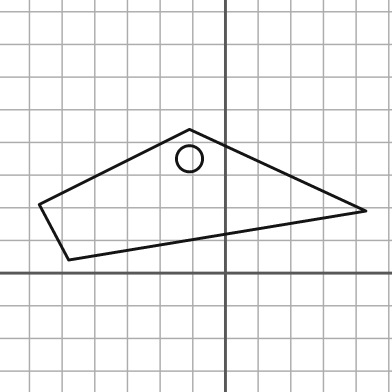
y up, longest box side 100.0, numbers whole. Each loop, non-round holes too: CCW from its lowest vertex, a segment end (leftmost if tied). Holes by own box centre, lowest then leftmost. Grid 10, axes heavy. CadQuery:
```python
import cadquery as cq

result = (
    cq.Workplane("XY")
    .moveTo(-48.0, 4.0)
    .lineTo(43.0, 19.0)
    .lineTo(-11.0, 44.0)
    .lineTo(-57.0, 21.0)
    .close()
    .moveTo(-11.0, 35.0)
    .circle(4.0)
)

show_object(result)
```